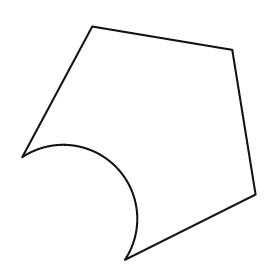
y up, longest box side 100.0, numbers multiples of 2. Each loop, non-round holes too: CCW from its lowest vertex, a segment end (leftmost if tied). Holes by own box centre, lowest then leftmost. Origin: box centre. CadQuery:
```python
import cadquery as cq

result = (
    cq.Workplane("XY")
    .moveTo(-6.0, -50.0)
    .lineTo(50.0, -22.0)
    .lineTo(40.0, 40.0)
    .lineTo(-20.0, 50.0)
    .lineTo(-50.0, -6.0)
    .threePointArc((-10.0, -10.0), (-6.0, -50.0))
    .close()
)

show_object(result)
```